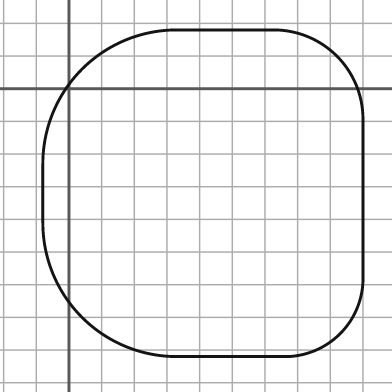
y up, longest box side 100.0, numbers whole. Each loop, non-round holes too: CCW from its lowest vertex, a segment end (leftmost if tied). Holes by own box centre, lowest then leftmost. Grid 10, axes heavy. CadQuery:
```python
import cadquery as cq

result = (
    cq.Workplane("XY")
    .moveTo(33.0, -82.0)
    .lineTo(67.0, -82.0)
    .threePointArc((83.0, -75.0), (90.0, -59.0))
    .lineTo(90.0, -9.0)
    .threePointArc((82.0, 10.0), (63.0, 18.0))
    .lineTo(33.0, 18.0)
    .threePointArc((4.0, 6.0), (-8.0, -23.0))
    .lineTo(-8.0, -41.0)
    .threePointArc((4.0, -70.0), (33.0, -82.0))
    .close()
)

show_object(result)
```